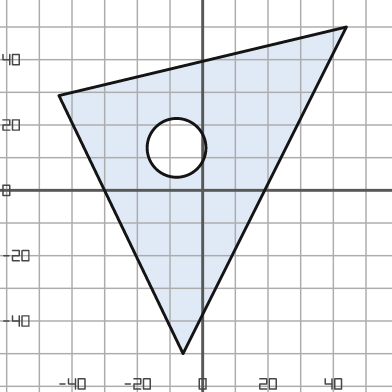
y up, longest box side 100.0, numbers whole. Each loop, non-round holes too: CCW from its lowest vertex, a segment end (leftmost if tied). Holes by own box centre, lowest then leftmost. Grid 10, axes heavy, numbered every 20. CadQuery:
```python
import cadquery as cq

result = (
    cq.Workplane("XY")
    .moveTo(-6.0, -50.0)
    .lineTo(44.0, 50.0)
    .lineTo(-44.0, 29.0)
    .close()
    .moveTo(-8.0, 13.0)
    .circle(9.0)
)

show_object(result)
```